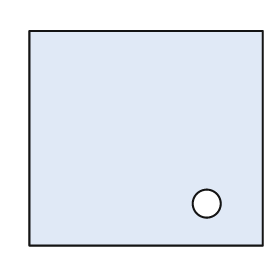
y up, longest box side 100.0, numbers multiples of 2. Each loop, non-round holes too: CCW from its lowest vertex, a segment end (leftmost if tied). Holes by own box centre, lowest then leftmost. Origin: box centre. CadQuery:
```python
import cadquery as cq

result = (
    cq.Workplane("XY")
    .moveTo(-50.0, -46.0)
    .lineTo(50.0, -46.0)
    .lineTo(50.0, 46.0)
    .lineTo(-50.0, 46.0)
    .close()
    .moveTo(26.0, -28.0)
    .circle(6.0)
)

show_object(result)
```